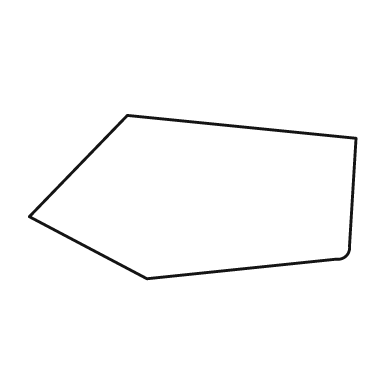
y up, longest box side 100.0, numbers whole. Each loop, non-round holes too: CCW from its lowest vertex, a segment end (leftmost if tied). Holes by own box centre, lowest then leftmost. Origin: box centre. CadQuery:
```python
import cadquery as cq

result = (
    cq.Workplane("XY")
    .moveTo(-14.0, -25.0)
    .lineTo(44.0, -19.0)
    .threePointArc((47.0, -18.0), (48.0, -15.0))
    .lineTo(50.0, 18.0)
    .lineTo(-20.0, 25.0)
    .lineTo(-50.0, -6.0)
    .close()
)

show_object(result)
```